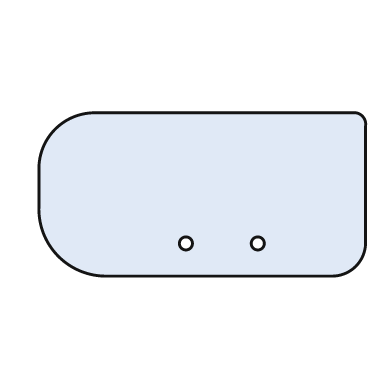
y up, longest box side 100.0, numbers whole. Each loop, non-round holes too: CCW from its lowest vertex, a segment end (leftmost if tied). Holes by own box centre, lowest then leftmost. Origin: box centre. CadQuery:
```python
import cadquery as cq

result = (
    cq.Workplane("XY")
    .moveTo(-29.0, -25.0)
    .lineTo(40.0, -25.0)
    .threePointArc((47.0, -22.0), (50.0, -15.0))
    .lineTo(50.0, 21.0)
    .threePointArc((49.0, 24.0), (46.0, 25.0))
    .lineTo(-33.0, 25.0)
    .threePointArc((-45.0, 20.0), (-50.0, 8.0))
    .lineTo(-50.0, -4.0)
    .threePointArc((-44.0, -19.0), (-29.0, -25.0))
    .close()
    .moveTo(-5.0, -15.0)
    .circle(2.0)
    .moveTo(17.0, -15.0)
    .circle(2.0)
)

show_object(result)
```